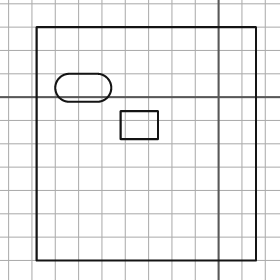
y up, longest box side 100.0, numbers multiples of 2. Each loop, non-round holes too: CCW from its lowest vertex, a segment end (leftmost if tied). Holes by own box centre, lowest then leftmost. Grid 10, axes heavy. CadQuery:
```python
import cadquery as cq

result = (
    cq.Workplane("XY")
    .moveTo(-78.0, -70.0)
    .lineTo(16.0, -70.0)
    .lineTo(16.0, 30.0)
    .lineTo(-78.0, 30.0)
    .close()
    .moveTo(-42.0, -18.0)
    .lineTo(-26.0, -18.0)
    .lineTo(-26.0, -6.0)
    .lineTo(-42.0, -6.0)
    .close()
    .moveTo(-64.0, -2.0)
    .lineTo(-52.0, -2.0)
    .threePointArc((-46.0, 4.0), (-52.0, 10.0))
    .lineTo(-64.0, 10.0)
    .threePointArc((-70.0, 4.0), (-64.0, -2.0))
    .close()
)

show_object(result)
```